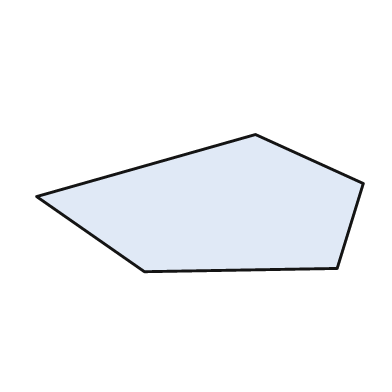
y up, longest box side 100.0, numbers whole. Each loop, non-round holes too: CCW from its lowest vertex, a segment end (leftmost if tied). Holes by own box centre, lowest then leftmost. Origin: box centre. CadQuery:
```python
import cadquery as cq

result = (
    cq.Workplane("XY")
    .moveTo(-17.0, -21.0)
    .lineTo(42.0, -20.0)
    .lineTo(50.0, 6.0)
    .lineTo(17.0, 21.0)
    .lineTo(-50.0, 2.0)
    .close()
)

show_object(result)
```